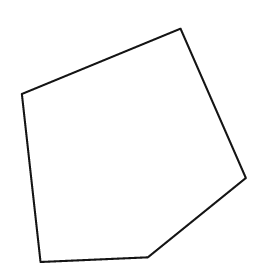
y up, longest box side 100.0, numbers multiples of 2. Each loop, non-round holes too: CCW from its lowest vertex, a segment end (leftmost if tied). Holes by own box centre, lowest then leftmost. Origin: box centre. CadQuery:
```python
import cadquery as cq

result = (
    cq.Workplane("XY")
    .moveTo(-40.0, -50.0)
    .lineTo(6.0, -48.0)
    .lineTo(48.0, -14.0)
    .lineTo(20.0, 50.0)
    .lineTo(-48.0, 22.0)
    .close()
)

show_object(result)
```